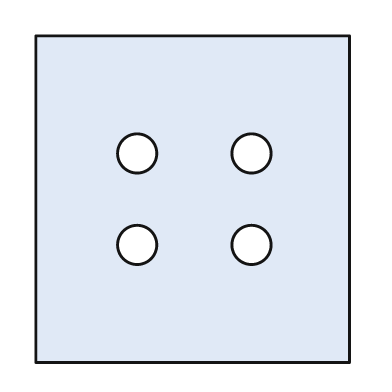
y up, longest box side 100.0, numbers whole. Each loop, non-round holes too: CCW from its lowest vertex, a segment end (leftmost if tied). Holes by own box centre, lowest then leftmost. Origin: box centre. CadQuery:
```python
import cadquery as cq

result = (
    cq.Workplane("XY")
    .moveTo(-48.0, -50.0)
    .lineTo(48.0, -50.0)
    .lineTo(48.0, 50.0)
    .lineTo(-48.0, 50.0)
    .close()
    .moveTo(-17.0, -14.0)
    .circle(6.0)
    .moveTo(18.0, -14.0)
    .circle(6.0)
    .moveTo(-17.0, 14.0)
    .circle(6.0)
    .moveTo(18.0, 14.0)
    .circle(6.0)
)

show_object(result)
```